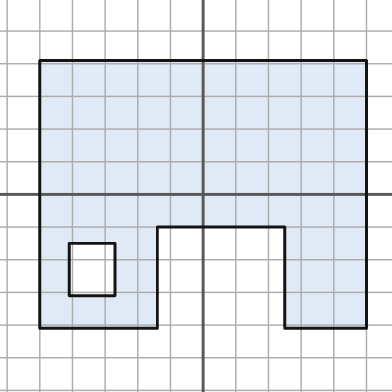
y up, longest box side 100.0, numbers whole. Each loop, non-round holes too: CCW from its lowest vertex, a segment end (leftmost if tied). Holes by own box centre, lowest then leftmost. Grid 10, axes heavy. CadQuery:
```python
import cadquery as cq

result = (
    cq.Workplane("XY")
    .moveTo(-50.0, -41.0)
    .lineTo(-14.0, -41.0)
    .lineTo(-14.0, -10.0)
    .lineTo(25.0, -10.0)
    .lineTo(25.0, -41.0)
    .lineTo(50.0, -41.0)
    .lineTo(50.0, 41.0)
    .lineTo(-50.0, 41.0)
    .close()
    .moveTo(-41.0, -31.0)
    .lineTo(-27.0, -31.0)
    .lineTo(-27.0, -15.0)
    .lineTo(-41.0, -15.0)
    .close()
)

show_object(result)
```